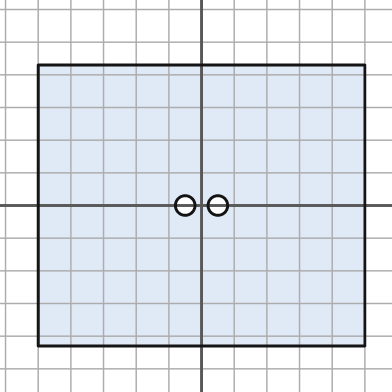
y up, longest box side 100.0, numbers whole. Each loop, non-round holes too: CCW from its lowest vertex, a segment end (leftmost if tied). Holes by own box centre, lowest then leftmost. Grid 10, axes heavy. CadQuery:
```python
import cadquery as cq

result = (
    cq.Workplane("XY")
    .moveTo(-50.0, -43.0)
    .lineTo(50.0, -43.0)
    .lineTo(50.0, 43.0)
    .lineTo(-50.0, 43.0)
    .close()
    .moveTo(-5.0, 0.0)
    .circle(3.0)
    .moveTo(5.0, 0.0)
    .circle(3.0)
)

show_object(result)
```